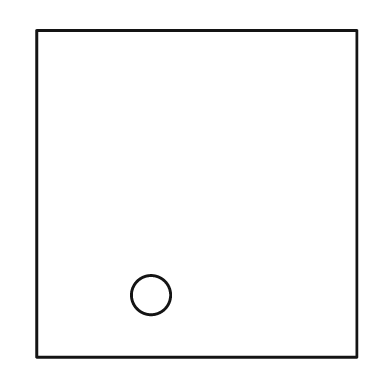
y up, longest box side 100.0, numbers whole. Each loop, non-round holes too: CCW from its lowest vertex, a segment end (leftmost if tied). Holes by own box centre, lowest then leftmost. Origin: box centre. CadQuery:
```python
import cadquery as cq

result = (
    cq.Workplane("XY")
    .moveTo(-49.0, -50.0)
    .lineTo(49.0, -50.0)
    .lineTo(49.0, 50.0)
    .lineTo(-49.0, 50.0)
    .close()
    .moveTo(-14.0, -31.0)
    .circle(6.0)
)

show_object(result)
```